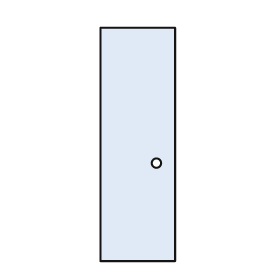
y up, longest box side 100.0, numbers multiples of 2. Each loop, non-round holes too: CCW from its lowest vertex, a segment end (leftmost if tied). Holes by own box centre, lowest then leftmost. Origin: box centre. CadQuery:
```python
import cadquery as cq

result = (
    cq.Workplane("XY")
    .moveTo(-16.0, -50.0)
    .lineTo(16.0, -50.0)
    .lineTo(16.0, 50.0)
    .lineTo(-16.0, 50.0)
    .close()
    .moveTo(8.0, -8.0)
    .circle(2.0)
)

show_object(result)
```